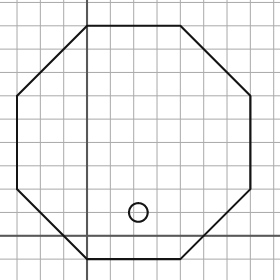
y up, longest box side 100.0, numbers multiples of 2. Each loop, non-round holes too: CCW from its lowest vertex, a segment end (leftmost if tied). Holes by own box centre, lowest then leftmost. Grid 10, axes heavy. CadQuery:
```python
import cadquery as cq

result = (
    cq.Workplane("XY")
    .moveTo(0.0, -10.0)
    .lineTo(40.0, -10.0)
    .lineTo(70.0, 20.0)
    .lineTo(70.0, 60.0)
    .lineTo(40.0, 90.0)
    .lineTo(0.0, 90.0)
    .lineTo(-30.0, 60.0)
    .lineTo(-30.0, 20.0)
    .close()
    .moveTo(22.0, 10.0)
    .circle(4.0)
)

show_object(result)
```